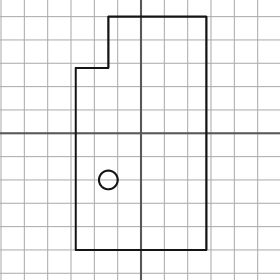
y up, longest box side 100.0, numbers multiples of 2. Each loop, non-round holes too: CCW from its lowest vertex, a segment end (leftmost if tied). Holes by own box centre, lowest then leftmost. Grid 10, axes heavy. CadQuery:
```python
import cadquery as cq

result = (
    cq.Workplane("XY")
    .moveTo(-28.0, -50.0)
    .lineTo(28.0, -50.0)
    .lineTo(28.0, 50.0)
    .lineTo(-14.0, 50.0)
    .lineTo(-14.0, 28.0)
    .lineTo(-28.0, 28.0)
    .close()
    .moveTo(-14.0, -20.0)
    .circle(4.0)
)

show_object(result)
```